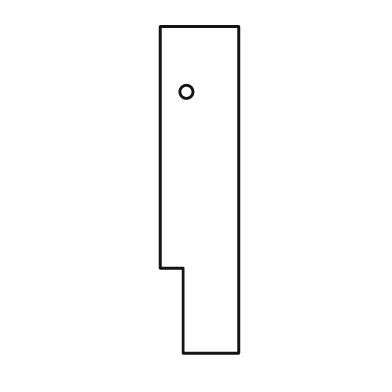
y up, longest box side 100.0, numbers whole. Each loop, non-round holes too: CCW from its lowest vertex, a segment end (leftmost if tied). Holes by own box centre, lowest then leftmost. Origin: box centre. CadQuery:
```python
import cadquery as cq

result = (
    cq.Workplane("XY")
    .moveTo(-5.0, -50.0)
    .lineTo(12.0, -50.0)
    .lineTo(12.0, 50.0)
    .lineTo(-12.0, 50.0)
    .lineTo(-12.0, -24.0)
    .lineTo(-5.0, -24.0)
    .close()
    .moveTo(-4.0, 30.0)
    .circle(2.0)
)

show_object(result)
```